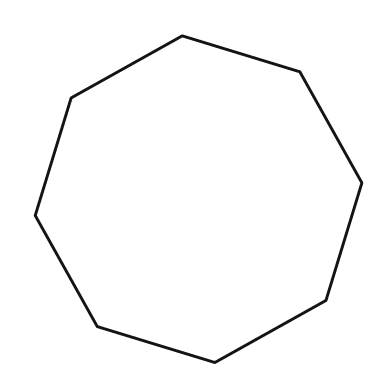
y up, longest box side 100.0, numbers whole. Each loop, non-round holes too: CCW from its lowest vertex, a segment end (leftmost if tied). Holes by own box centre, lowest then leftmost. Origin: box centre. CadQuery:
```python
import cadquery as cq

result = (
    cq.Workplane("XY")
    .moveTo(5.0, -50.0)
    .lineTo(39.0, -31.0)
    .lineTo(50.0, 5.0)
    .lineTo(31.0, 39.0)
    .lineTo(-5.0, 50.0)
    .lineTo(-39.0, 31.0)
    .lineTo(-50.0, -5.0)
    .lineTo(-31.0, -39.0)
    .close()
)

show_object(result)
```